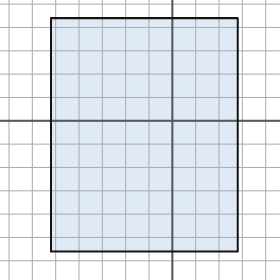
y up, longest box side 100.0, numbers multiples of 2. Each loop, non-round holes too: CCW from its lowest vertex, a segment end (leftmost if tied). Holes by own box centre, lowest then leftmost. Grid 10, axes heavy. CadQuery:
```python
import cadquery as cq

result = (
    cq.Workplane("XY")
    .moveTo(-52.0, -56.0)
    .lineTo(28.0, -56.0)
    .lineTo(28.0, 44.0)
    .lineTo(-52.0, 44.0)
    .close()
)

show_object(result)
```